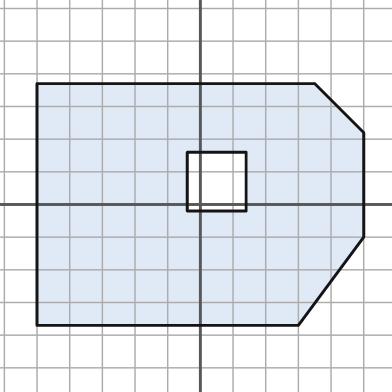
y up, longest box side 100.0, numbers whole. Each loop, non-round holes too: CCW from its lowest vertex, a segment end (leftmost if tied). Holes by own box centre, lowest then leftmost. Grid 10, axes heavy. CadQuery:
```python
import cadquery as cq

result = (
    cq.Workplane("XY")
    .moveTo(-50.0, -37.0)
    .lineTo(30.0, -37.0)
    .lineTo(50.0, -10.0)
    .lineTo(50.0, 22.0)
    .lineTo(35.0, 37.0)
    .lineTo(-50.0, 37.0)
    .close()
    .moveTo(-4.0, -2.0)
    .lineTo(14.0, -2.0)
    .lineTo(14.0, 16.0)
    .lineTo(-4.0, 16.0)
    .close()
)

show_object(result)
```